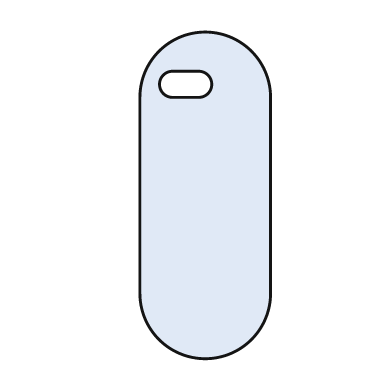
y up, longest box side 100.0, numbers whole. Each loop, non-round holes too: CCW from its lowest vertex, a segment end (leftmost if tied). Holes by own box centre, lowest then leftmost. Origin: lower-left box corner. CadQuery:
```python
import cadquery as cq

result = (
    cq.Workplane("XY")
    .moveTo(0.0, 20.0)
    .threePointArc((20.0, 0.0), (40.0, 20.0))
    .lineTo(40.0, 80.0)
    .threePointArc((20.0, 100.0), (0.0, 80.0))
    .close()
    .moveTo(10.0, 80.0)
    .lineTo(18.0, 80.0)
    .threePointArc((22.0, 84.0), (18.0, 88.0))
    .lineTo(10.0, 88.0)
    .threePointArc((6.0, 84.0), (10.0, 80.0))
    .close()
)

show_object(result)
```